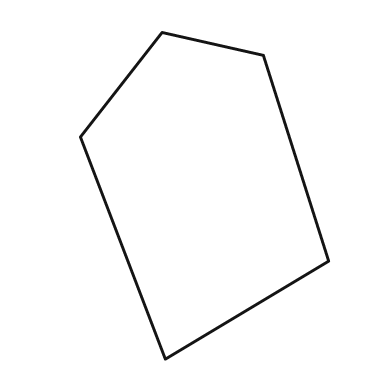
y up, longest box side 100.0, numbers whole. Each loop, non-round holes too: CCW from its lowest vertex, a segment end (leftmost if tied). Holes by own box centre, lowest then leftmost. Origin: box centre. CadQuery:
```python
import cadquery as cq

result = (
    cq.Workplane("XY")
    .moveTo(-12.0, -50.0)
    .lineTo(38.0, -20.0)
    .lineTo(18.0, 43.0)
    .lineTo(-13.0, 50.0)
    .lineTo(-38.0, 18.0)
    .close()
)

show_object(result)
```